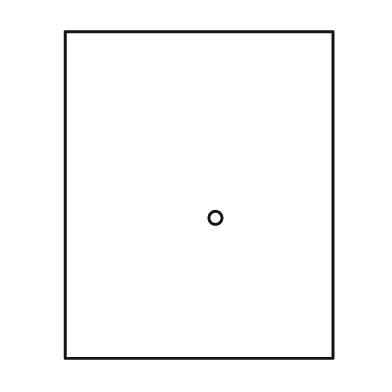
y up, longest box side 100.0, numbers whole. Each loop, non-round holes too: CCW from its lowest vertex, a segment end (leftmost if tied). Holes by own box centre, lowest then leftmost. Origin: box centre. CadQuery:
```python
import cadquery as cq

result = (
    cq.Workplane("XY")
    .moveTo(-41.0, -50.0)
    .lineTo(41.0, -50.0)
    .lineTo(41.0, 50.0)
    .lineTo(-41.0, 50.0)
    .close()
    .moveTo(5.0, -7.0)
    .circle(2.0)
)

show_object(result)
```